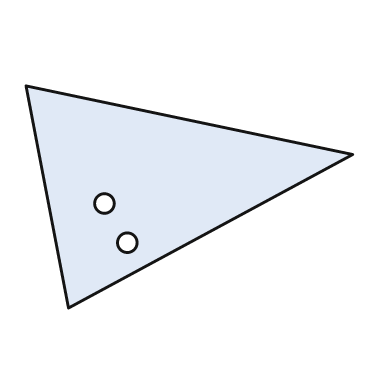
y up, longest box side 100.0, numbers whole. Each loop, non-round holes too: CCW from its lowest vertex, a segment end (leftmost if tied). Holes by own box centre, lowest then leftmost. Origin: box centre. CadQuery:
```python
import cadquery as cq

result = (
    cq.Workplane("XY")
    .moveTo(-37.0, -34.0)
    .lineTo(50.0, 13.0)
    .lineTo(-50.0, 34.0)
    .close()
    .moveTo(-19.0, -14.0)
    .circle(3.0)
    .moveTo(-26.0, -2.0)
    .circle(3.0)
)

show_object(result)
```